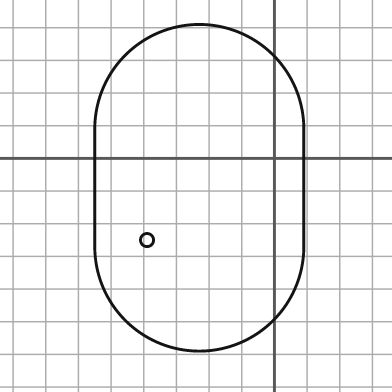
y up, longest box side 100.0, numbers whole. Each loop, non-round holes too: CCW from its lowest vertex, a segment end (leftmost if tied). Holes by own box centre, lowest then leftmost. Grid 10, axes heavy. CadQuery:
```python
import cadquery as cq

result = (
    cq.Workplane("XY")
    .moveTo(-55.0, -27.0)
    .threePointArc((-23.0, -59.0), (9.0, -27.0))
    .lineTo(9.0, 9.0)
    .threePointArc((-23.0, 41.0), (-55.0, 9.0))
    .close()
    .moveTo(-39.0, -25.0)
    .circle(2.0)
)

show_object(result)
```